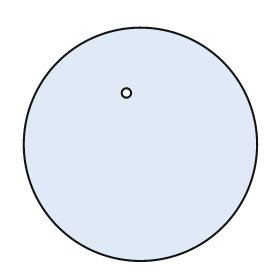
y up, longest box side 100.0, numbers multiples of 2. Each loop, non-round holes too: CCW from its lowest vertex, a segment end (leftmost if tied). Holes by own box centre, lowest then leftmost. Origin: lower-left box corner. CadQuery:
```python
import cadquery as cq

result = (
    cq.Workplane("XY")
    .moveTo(50.0, 50.0)
    .circle(50.0)
    .moveTo(44.0, 72.0)
    .circle(2.0)
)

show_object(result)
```